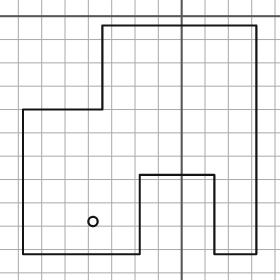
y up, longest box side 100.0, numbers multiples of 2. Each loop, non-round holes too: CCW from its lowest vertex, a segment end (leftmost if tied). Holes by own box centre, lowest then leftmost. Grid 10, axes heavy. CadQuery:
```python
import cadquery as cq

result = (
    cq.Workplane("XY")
    .moveTo(-68.0, -102.0)
    .lineTo(-18.0, -102.0)
    .lineTo(-18.0, -68.0)
    .lineTo(14.0, -68.0)
    .lineTo(14.0, -102.0)
    .lineTo(32.0, -102.0)
    .lineTo(32.0, -4.0)
    .lineTo(-34.0, -4.0)
    .lineTo(-34.0, -40.0)
    .lineTo(-68.0, -40.0)
    .close()
    .moveTo(-38.0, -88.0)
    .circle(2.0)
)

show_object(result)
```